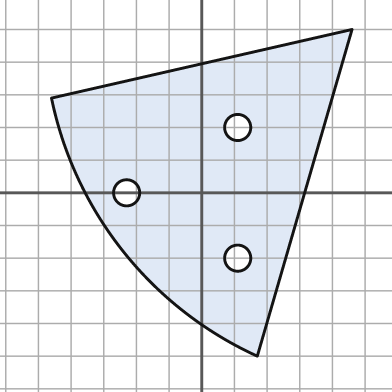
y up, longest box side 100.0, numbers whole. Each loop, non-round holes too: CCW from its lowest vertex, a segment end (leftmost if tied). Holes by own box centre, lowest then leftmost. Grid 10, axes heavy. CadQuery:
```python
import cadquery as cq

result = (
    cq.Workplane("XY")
    .moveTo(17.0, -50.0)
    .lineTo(46.0, 50.0)
    .lineTo(-46.0, 29.0)
    .threePointArc((-24.0, -18.0), (17.0, -50.0))
    .close()
    .moveTo(11.0, -20.0)
    .circle(4.0)
    .moveTo(-23.0, 0.0)
    .circle(4.0)
    .moveTo(11.0, 20.0)
    .circle(4.0)
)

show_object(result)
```